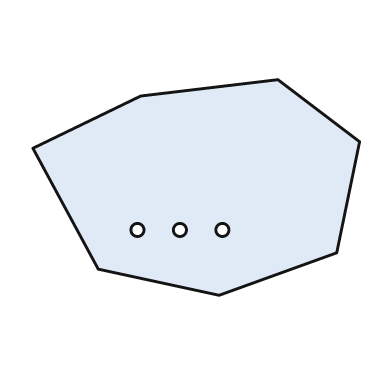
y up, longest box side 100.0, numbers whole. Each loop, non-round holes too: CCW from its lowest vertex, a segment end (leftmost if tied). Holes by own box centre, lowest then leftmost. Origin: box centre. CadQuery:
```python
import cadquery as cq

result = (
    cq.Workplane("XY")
    .moveTo(7.0, -33.0)
    .lineTo(43.0, -20.0)
    .lineTo(50.0, 14.0)
    .lineTo(25.0, 33.0)
    .lineTo(-17.0, 28.0)
    .lineTo(-50.0, 12.0)
    .lineTo(-30.0, -25.0)
    .close()
    .moveTo(-18.0, -13.0)
    .circle(2.0)
    .moveTo(-5.0, -13.0)
    .circle(2.0)
    .moveTo(8.0, -13.0)
    .circle(2.0)
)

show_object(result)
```